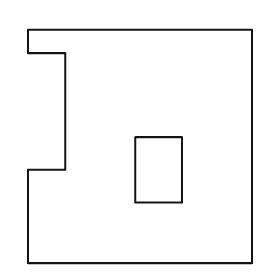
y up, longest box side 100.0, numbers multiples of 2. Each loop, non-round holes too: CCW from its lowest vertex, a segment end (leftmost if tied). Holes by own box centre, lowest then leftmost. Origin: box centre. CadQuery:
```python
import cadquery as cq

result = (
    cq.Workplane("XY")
    .moveTo(-48.0, -50.0)
    .lineTo(48.0, -50.0)
    .lineTo(48.0, 50.0)
    .lineTo(-48.0, 50.0)
    .lineTo(-48.0, 40.0)
    .lineTo(-32.0, 40.0)
    .lineTo(-32.0, -10.0)
    .lineTo(-48.0, -10.0)
    .close()
    .moveTo(-2.0, -24.0)
    .lineTo(18.0, -24.0)
    .lineTo(18.0, 4.0)
    .lineTo(-2.0, 4.0)
    .close()
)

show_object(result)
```